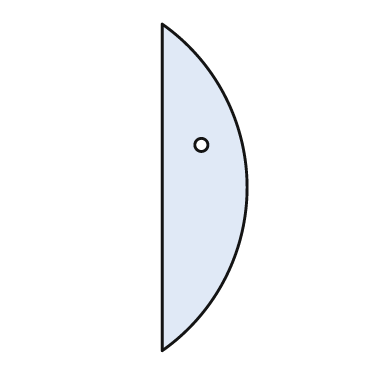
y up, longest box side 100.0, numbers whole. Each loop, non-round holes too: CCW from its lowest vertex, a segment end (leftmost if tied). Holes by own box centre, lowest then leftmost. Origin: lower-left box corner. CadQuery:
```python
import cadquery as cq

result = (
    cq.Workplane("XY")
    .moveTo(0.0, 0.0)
    .threePointArc((26.0, 50.0), (0.0, 100.0))
    .close()
    .moveTo(12.0, 63.0)
    .circle(2.0)
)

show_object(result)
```